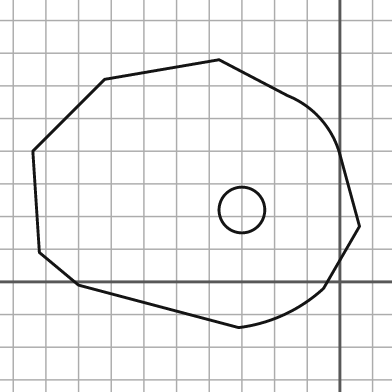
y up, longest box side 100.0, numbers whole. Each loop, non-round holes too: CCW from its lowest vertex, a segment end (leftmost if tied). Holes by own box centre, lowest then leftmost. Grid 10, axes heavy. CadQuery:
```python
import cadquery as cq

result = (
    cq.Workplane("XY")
    .moveTo(-31.0, -14.0)
    .threePointArc((-17.0, -10.0), (-5.0, -2.0))
    .lineTo(6.0, 17.0)
    .lineTo(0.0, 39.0)
    .threePointArc((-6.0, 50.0), (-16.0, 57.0))
    .lineTo(-37.0, 68.0)
    .lineTo(-72.0, 62.0)
    .lineTo(-94.0, 40.0)
    .lineTo(-92.0, 9.0)
    .lineTo(-80.0, -1.0)
    .close()
    .moveTo(-30.0, 22.0)
    .circle(7.0)
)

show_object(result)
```